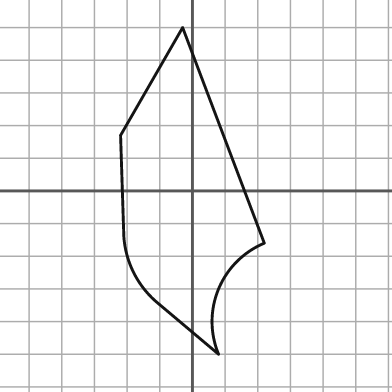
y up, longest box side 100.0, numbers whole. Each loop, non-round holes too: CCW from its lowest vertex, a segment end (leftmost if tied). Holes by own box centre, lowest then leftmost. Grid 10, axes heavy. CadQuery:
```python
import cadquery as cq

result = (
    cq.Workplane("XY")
    .moveTo(8.0, -50.0)
    .threePointArc((8.0, -30.0), (22.0, -16.0))
    .lineTo(-3.0, 50.0)
    .lineTo(-22.0, 17.0)
    .lineTo(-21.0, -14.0)
    .threePointArc((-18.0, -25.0), (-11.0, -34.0))
    .close()
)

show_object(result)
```